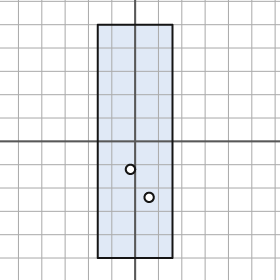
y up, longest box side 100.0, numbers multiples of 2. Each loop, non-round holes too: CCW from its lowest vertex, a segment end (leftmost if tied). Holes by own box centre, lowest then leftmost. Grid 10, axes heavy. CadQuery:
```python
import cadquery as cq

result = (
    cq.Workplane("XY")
    .moveTo(-16.0, -50.0)
    .lineTo(16.0, -50.0)
    .lineTo(16.0, 50.0)
    .lineTo(-16.0, 50.0)
    .close()
    .moveTo(6.0, -24.0)
    .circle(2.0)
    .moveTo(-2.0, -12.0)
    .circle(2.0)
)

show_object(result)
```